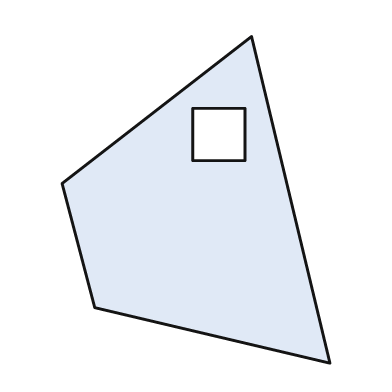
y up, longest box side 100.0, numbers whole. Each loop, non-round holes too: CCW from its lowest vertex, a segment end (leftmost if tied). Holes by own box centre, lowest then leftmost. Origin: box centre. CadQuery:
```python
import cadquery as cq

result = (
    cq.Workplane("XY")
    .moveTo(41.0, -50.0)
    .lineTo(17.0, 50.0)
    .lineTo(-41.0, 5.0)
    .lineTo(-31.0, -33.0)
    .close()
    .moveTo(-1.0, 12.0)
    .lineTo(15.0, 12.0)
    .lineTo(15.0, 28.0)
    .lineTo(-1.0, 28.0)
    .close()
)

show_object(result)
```